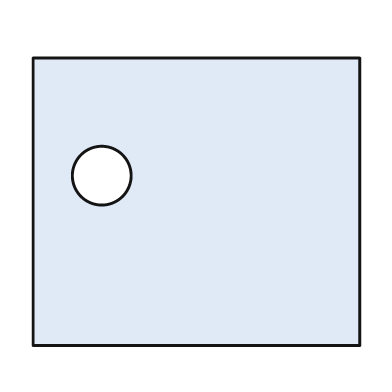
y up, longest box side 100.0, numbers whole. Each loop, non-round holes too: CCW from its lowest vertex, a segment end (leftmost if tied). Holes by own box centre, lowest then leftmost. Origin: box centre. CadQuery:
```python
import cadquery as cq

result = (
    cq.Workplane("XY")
    .moveTo(-50.0, -44.0)
    .lineTo(50.0, -44.0)
    .lineTo(50.0, 44.0)
    .lineTo(-50.0, 44.0)
    .close()
    .moveTo(-29.0, 8.0)
    .circle(9.0)
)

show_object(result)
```